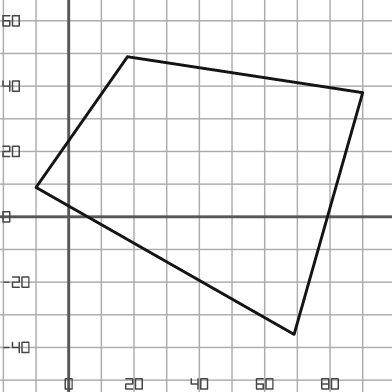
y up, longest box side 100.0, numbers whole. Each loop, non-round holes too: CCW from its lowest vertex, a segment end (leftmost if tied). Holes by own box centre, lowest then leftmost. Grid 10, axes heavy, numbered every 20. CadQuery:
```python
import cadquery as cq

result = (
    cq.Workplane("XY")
    .moveTo(69.0, -36.0)
    .lineTo(90.0, 38.0)
    .lineTo(18.0, 49.0)
    .lineTo(-10.0, 9.0)
    .close()
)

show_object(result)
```